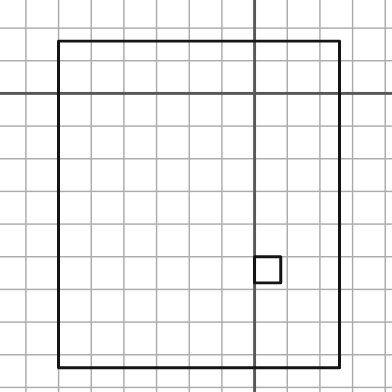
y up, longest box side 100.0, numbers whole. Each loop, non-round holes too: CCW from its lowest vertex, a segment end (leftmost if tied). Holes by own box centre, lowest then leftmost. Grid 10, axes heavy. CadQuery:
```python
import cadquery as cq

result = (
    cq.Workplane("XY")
    .moveTo(-60.0, -84.0)
    .lineTo(26.0, -84.0)
    .lineTo(26.0, 16.0)
    .lineTo(-60.0, 16.0)
    .close()
    .moveTo(0.0, -58.0)
    .lineTo(8.0, -58.0)
    .lineTo(8.0, -50.0)
    .lineTo(0.0, -50.0)
    .close()
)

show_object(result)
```